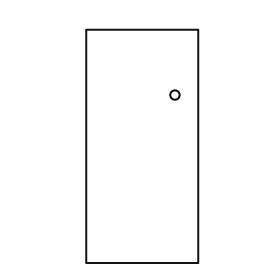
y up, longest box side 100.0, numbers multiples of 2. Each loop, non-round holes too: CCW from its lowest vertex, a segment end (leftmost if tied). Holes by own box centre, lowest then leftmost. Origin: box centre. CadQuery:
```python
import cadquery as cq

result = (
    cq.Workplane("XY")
    .moveTo(-24.0, -50.0)
    .lineTo(24.0, -50.0)
    .lineTo(24.0, 50.0)
    .lineTo(-24.0, 50.0)
    .close()
    .moveTo(14.0, 22.0)
    .circle(2.0)
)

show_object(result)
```